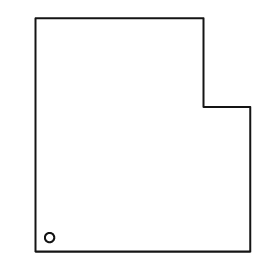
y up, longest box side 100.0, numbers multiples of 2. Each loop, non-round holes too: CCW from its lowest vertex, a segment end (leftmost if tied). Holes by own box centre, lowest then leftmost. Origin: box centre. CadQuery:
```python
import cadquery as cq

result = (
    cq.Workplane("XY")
    .moveTo(-46.0, -50.0)
    .lineTo(46.0, -50.0)
    .lineTo(46.0, 12.0)
    .lineTo(26.0, 12.0)
    .lineTo(26.0, 50.0)
    .lineTo(-46.0, 50.0)
    .close()
    .moveTo(-40.0, -44.0)
    .circle(2.0)
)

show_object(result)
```